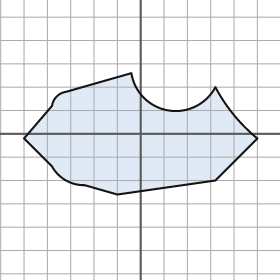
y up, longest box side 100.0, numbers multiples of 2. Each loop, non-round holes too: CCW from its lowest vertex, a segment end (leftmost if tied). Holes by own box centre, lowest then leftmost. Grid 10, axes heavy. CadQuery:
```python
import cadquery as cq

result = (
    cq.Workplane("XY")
    .moveTo(-10.0, -26.0)
    .lineTo(32.0, -20.0)
    .lineTo(50.0, -2.0)
    .threePointArc((40.0, 8.0), (32.0, 20.0))
    .threePointArc((12.0, 10.0), (-4.0, 26.0))
    .lineTo(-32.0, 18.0)
    .threePointArc((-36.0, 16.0), (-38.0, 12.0))
    .lineTo(-50.0, -2.0)
    .lineTo(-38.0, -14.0)
    .threePointArc((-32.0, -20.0), (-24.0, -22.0))
    .close()
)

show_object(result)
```